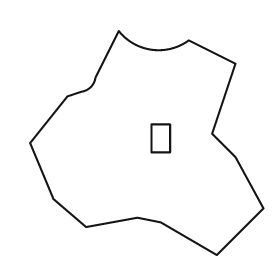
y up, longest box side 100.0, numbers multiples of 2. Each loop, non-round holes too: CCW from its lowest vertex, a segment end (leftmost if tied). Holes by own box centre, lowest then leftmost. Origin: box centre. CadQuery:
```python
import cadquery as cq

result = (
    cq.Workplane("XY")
    .moveTo(30.0, -48.0)
    .lineTo(50.0, -28.0)
    .lineTo(38.0, -6.0)
    .lineTo(28.0, 4.0)
    .lineTo(38.0, 34.0)
    .lineTo(18.0, 44.0)
    .threePointArc((2.0, 40.0), (-12.0, 48.0))
    .lineTo(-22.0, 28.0)
    .threePointArc((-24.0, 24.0), (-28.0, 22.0))
    .lineTo(-34.0, 20.0)
    .lineTo(-50.0, 0.0)
    .lineTo(-40.0, -24.0)
    .lineTo(-26.0, -36.0)
    .lineTo(-4.0, -32.0)
    .lineTo(6.0, -34.0)
    .close()
    .moveTo(2.0, -4.0)
    .lineTo(10.0, -4.0)
    .lineTo(10.0, 8.0)
    .lineTo(2.0, 8.0)
    .close()
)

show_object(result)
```